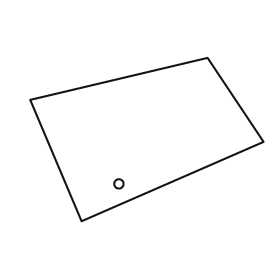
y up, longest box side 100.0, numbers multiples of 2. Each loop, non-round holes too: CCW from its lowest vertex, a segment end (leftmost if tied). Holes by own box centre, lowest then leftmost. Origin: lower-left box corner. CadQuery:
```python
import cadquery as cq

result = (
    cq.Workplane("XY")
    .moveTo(22.0, 0.0)
    .lineTo(100.0, 34.0)
    .lineTo(76.0, 70.0)
    .lineTo(0.0, 52.0)
    .close()
    .moveTo(38.0, 16.0)
    .circle(2.0)
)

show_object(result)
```